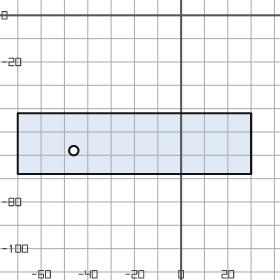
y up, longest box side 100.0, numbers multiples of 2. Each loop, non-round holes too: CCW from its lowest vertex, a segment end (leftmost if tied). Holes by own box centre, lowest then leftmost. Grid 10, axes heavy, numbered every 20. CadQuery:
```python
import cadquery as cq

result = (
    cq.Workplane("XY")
    .moveTo(-70.0, -68.0)
    .lineTo(30.0, -68.0)
    .lineTo(30.0, -42.0)
    .lineTo(-70.0, -42.0)
    .close()
    .moveTo(-46.0, -58.0)
    .circle(2.0)
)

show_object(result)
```